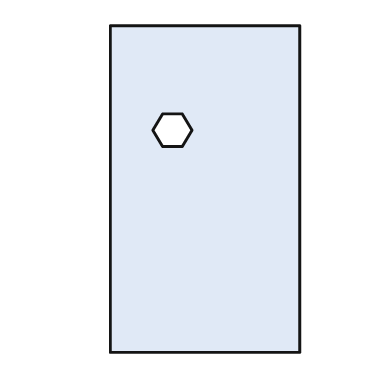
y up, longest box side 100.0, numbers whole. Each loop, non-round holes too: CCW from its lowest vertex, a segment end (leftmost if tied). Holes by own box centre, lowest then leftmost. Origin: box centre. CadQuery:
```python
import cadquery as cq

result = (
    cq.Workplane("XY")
    .moveTo(-29.0, -50.0)
    .lineTo(29.0, -50.0)
    .lineTo(29.0, 50.0)
    .lineTo(-29.0, 50.0)
    .close()
    .moveTo(-13.0, 13.0)
    .lineTo(-7.0, 13.0)
    .lineTo(-4.0, 18.0)
    .lineTo(-7.0, 23.0)
    .lineTo(-13.0, 23.0)
    .lineTo(-16.0, 18.0)
    .close()
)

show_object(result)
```